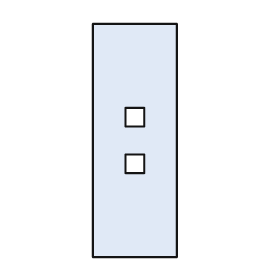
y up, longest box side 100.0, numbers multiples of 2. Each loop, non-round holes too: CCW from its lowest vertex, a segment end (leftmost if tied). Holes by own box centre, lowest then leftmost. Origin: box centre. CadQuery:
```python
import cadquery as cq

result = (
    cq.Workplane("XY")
    .moveTo(-18.0, -50.0)
    .lineTo(18.0, -50.0)
    .lineTo(18.0, 50.0)
    .lineTo(-18.0, 50.0)
    .close()
    .moveTo(-4.0, -14.0)
    .lineTo(4.0, -14.0)
    .lineTo(4.0, -6.0)
    .lineTo(-4.0, -6.0)
    .close()
    .moveTo(-4.0, 6.0)
    .lineTo(4.0, 6.0)
    .lineTo(4.0, 14.0)
    .lineTo(-4.0, 14.0)
    .close()
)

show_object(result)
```